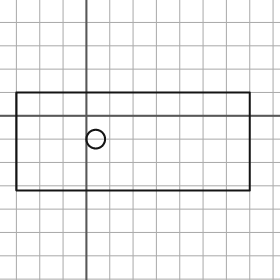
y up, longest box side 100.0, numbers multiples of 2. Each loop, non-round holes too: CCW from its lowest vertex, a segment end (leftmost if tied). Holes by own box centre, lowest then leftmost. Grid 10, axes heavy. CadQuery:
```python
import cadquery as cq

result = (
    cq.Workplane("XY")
    .moveTo(-30.0, -32.0)
    .lineTo(70.0, -32.0)
    .lineTo(70.0, 10.0)
    .lineTo(-30.0, 10.0)
    .close()
    .moveTo(4.0, -10.0)
    .circle(4.0)
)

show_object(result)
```